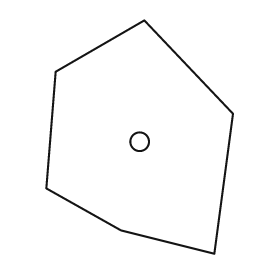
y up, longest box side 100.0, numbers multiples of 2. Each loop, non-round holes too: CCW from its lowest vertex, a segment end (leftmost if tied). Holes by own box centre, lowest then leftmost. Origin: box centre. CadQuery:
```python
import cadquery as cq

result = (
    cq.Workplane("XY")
    .moveTo(32.0, -50.0)
    .lineTo(40.0, 10.0)
    .lineTo(2.0, 50.0)
    .lineTo(-36.0, 28.0)
    .lineTo(-40.0, -22.0)
    .lineTo(-8.0, -40.0)
    .close()
    .moveTo(0.0, -2.0)
    .circle(4.0)
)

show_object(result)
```